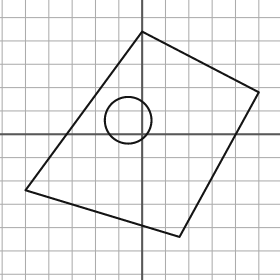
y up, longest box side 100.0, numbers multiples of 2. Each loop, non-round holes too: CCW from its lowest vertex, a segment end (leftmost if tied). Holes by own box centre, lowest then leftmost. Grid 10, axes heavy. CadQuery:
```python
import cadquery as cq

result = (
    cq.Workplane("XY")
    .moveTo(16.0, -44.0)
    .lineTo(50.0, 18.0)
    .lineTo(0.0, 44.0)
    .lineTo(-50.0, -24.0)
    .close()
    .moveTo(-6.0, 6.0)
    .circle(10.0)
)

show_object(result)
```